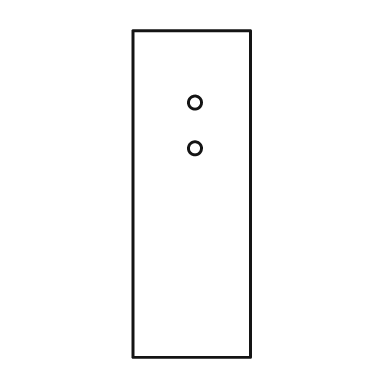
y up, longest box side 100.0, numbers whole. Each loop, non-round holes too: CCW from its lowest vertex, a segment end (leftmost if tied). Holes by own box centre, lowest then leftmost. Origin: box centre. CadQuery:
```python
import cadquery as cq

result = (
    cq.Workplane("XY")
    .moveTo(-18.0, -50.0)
    .lineTo(18.0, -50.0)
    .lineTo(18.0, 50.0)
    .lineTo(-18.0, 50.0)
    .close()
    .moveTo(1.0, 14.0)
    .circle(2.0)
    .moveTo(1.0, 28.0)
    .circle(2.0)
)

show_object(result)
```